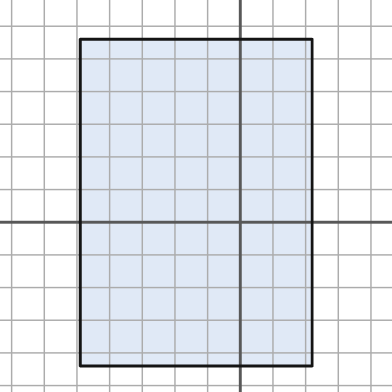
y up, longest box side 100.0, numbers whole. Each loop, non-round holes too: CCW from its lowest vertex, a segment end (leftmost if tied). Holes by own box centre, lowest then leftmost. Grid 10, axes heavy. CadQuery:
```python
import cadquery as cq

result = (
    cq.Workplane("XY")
    .moveTo(-49.0, -44.0)
    .lineTo(22.0, -44.0)
    .lineTo(22.0, 56.0)
    .lineTo(-49.0, 56.0)
    .close()
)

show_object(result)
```